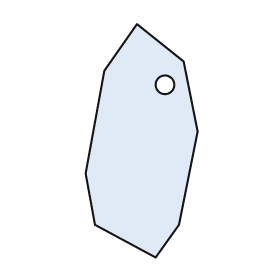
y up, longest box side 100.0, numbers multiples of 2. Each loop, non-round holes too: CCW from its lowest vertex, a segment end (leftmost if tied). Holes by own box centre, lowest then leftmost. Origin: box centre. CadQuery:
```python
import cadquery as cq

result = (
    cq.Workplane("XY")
    .moveTo(6.0, -50.0)
    .lineTo(16.0, -36.0)
    .lineTo(24.0, 4.0)
    .lineTo(18.0, 34.0)
    .lineTo(-2.0, 50.0)
    .lineTo(-16.0, 30.0)
    .lineTo(-24.0, -14.0)
    .lineTo(-20.0, -36.0)
    .close()
    .moveTo(10.0, 24.0)
    .circle(4.0)
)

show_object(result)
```